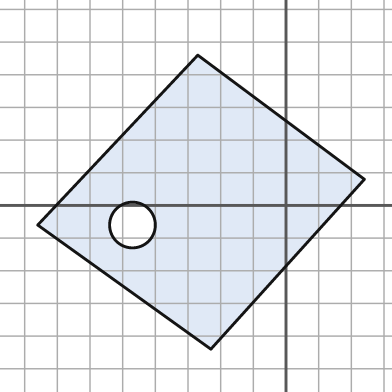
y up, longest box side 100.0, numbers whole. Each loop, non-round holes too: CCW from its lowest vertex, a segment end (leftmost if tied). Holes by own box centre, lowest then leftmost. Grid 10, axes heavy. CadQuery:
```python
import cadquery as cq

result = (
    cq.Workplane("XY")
    .moveTo(-23.0, -44.0)
    .lineTo(24.0, 8.0)
    .lineTo(-27.0, 46.0)
    .lineTo(-76.0, -6.0)
    .close()
    .moveTo(-47.0, -6.0)
    .circle(7.0)
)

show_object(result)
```